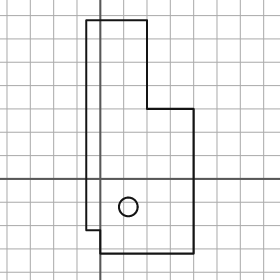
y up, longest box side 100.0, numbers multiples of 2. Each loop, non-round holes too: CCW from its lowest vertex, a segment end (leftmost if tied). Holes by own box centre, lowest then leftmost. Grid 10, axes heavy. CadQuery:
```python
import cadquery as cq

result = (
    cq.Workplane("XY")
    .moveTo(0.0, -32.0)
    .lineTo(40.0, -32.0)
    .lineTo(40.0, 30.0)
    .lineTo(20.0, 30.0)
    .lineTo(20.0, 68.0)
    .lineTo(-6.0, 68.0)
    .lineTo(-6.0, -22.0)
    .lineTo(0.0, -22.0)
    .close()
    .moveTo(12.0, -12.0)
    .circle(4.0)
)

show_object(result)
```